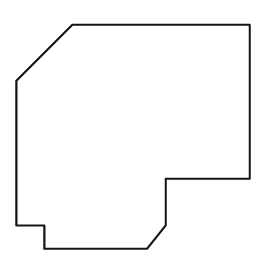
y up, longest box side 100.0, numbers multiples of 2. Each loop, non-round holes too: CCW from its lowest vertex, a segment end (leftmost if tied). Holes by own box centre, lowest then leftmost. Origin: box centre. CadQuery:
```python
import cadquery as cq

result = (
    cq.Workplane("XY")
    .moveTo(-38.0, -48.0)
    .lineTo(6.0, -48.0)
    .lineTo(14.0, -38.0)
    .lineTo(14.0, -18.0)
    .lineTo(50.0, -18.0)
    .lineTo(50.0, 48.0)
    .lineTo(-26.0, 48.0)
    .lineTo(-50.0, 24.0)
    .lineTo(-50.0, -38.0)
    .lineTo(-38.0, -38.0)
    .close()
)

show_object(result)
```